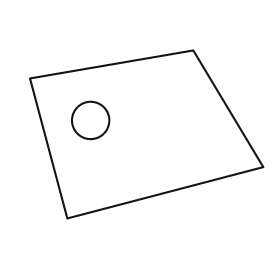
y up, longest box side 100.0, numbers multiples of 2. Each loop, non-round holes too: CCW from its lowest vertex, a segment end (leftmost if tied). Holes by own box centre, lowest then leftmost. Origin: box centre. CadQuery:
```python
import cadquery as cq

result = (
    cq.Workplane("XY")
    .moveTo(-34.0, -36.0)
    .lineTo(50.0, -14.0)
    .lineTo(20.0, 36.0)
    .lineTo(-50.0, 24.0)
    .close()
    .moveTo(-24.0, 6.0)
    .circle(8.0)
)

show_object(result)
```